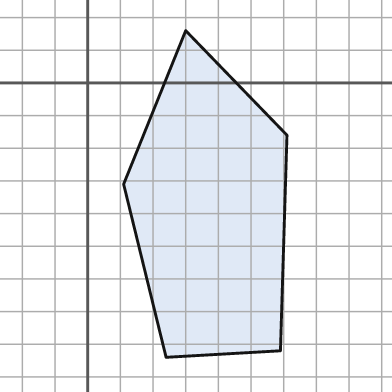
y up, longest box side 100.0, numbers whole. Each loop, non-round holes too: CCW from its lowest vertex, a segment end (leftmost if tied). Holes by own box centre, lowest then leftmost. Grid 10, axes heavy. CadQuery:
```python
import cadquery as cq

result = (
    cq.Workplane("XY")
    .moveTo(24.0, -84.0)
    .lineTo(59.0, -82.0)
    .lineTo(61.0, -16.0)
    .lineTo(30.0, 16.0)
    .lineTo(11.0, -31.0)
    .close()
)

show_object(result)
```